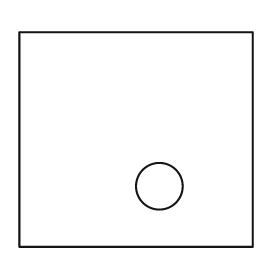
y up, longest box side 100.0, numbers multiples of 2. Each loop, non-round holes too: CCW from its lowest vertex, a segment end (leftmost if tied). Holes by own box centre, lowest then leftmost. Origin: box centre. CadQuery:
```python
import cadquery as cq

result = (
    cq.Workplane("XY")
    .moveTo(-50.0, -46.0)
    .lineTo(50.0, -46.0)
    .lineTo(50.0, 46.0)
    .lineTo(-50.0, 46.0)
    .close()
    .moveTo(10.0, -20.0)
    .circle(10.0)
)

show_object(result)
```